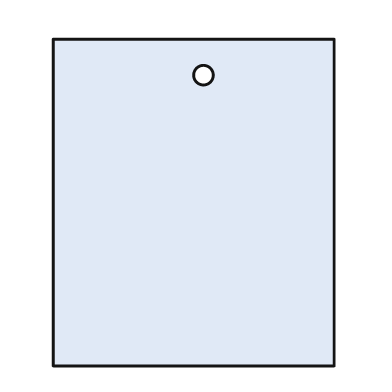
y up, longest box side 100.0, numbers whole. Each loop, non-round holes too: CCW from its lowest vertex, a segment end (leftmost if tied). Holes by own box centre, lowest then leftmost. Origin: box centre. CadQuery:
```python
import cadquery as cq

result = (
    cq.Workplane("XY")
    .moveTo(-43.0, -50.0)
    .lineTo(43.0, -50.0)
    .lineTo(43.0, 50.0)
    .lineTo(-43.0, 50.0)
    .close()
    .moveTo(3.0, 39.0)
    .circle(3.0)
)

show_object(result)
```